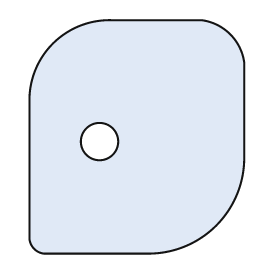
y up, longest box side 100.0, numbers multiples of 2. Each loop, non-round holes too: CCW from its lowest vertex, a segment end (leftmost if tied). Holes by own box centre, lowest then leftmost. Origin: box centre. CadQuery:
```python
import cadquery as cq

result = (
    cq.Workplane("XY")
    .moveTo(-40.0, -50.0)
    .lineTo(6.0, -50.0)
    .threePointArc((34.0, -38.0), (46.0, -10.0))
    .lineTo(46.0, 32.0)
    .threePointArc((40.0, 44.0), (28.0, 50.0))
    .lineTo(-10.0, 50.0)
    .threePointArc((-36.0, 40.0), (-46.0, 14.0))
    .lineTo(-46.0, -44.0)
    .threePointArc((-44.0, -48.0), (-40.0, -50.0))
    .close()
    .moveTo(-16.0, -2.0)
    .circle(8.0)
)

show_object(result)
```